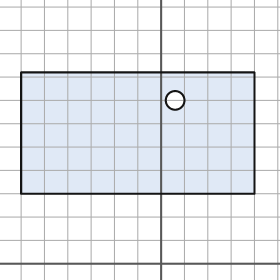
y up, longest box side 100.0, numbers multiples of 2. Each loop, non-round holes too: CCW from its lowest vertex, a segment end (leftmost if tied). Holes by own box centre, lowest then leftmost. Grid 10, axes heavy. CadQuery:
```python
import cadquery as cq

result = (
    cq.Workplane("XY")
    .moveTo(-60.0, 30.0)
    .lineTo(40.0, 30.0)
    .lineTo(40.0, 82.0)
    .lineTo(-60.0, 82.0)
    .close()
    .moveTo(6.0, 70.0)
    .circle(4.0)
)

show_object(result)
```